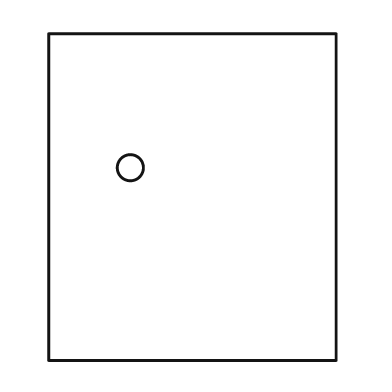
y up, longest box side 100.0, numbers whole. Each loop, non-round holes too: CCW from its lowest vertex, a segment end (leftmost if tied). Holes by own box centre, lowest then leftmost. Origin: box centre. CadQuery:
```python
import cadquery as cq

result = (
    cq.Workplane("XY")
    .moveTo(-44.0, -50.0)
    .lineTo(44.0, -50.0)
    .lineTo(44.0, 50.0)
    .lineTo(-44.0, 50.0)
    .close()
    .moveTo(-19.0, 9.0)
    .circle(4.0)
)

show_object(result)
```